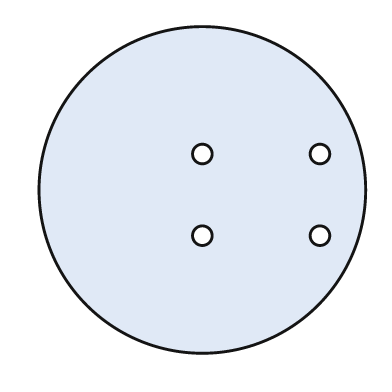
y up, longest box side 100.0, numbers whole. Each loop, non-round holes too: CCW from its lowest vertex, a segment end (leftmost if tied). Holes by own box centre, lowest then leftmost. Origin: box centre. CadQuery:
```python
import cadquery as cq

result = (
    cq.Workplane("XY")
    .moveTo(0.0, 0.0)
    .circle(50.0)
    .moveTo(0.0, -14.0)
    .circle(3.0)
    .moveTo(36.0, -14.0)
    .circle(3.0)
    .moveTo(0.0, 11.0)
    .circle(3.0)
    .moveTo(36.0, 11.0)
    .circle(3.0)
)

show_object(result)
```